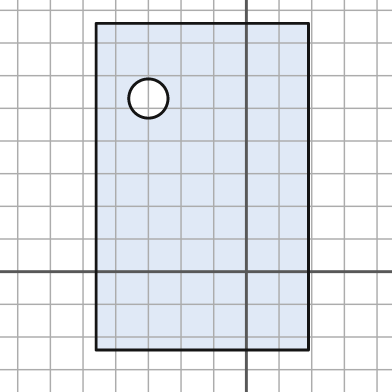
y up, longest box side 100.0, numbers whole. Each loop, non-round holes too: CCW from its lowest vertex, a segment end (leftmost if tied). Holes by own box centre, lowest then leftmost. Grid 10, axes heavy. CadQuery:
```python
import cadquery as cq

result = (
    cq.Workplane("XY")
    .moveTo(-46.0, -24.0)
    .lineTo(19.0, -24.0)
    .lineTo(19.0, 76.0)
    .lineTo(-46.0, 76.0)
    .close()
    .moveTo(-30.0, 53.0)
    .circle(6.0)
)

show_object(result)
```